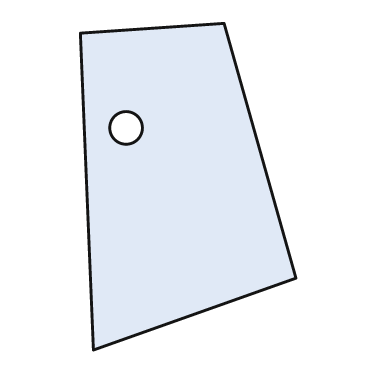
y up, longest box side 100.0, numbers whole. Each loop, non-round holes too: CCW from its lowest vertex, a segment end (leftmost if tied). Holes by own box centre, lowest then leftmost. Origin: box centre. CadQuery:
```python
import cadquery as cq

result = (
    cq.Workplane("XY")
    .moveTo(-29.0, -50.0)
    .lineTo(33.0, -28.0)
    .lineTo(11.0, 50.0)
    .lineTo(-33.0, 47.0)
    .close()
    .moveTo(-19.0, 18.0)
    .circle(5.0)
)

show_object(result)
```